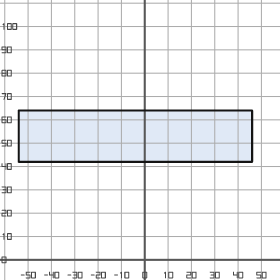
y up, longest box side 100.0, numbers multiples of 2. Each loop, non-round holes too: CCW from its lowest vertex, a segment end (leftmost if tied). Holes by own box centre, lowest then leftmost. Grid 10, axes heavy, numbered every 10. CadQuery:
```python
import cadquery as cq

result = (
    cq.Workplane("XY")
    .moveTo(-54.0, 42.0)
    .lineTo(46.0, 42.0)
    .lineTo(46.0, 64.0)
    .lineTo(-54.0, 64.0)
    .close()
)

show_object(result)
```